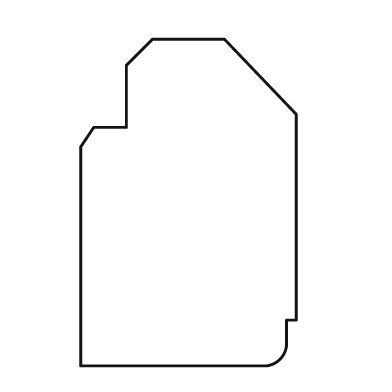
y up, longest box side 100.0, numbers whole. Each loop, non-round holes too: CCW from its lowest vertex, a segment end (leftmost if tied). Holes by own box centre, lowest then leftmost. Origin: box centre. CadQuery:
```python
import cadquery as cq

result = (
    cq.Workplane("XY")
    .moveTo(-33.0, -50.0)
    .lineTo(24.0, -50.0)
    .threePointArc((28.0, -48.0), (30.0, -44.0))
    .lineTo(30.0, -36.0)
    .lineTo(33.0, -36.0)
    .lineTo(33.0, 27.0)
    .lineTo(11.0, 50.0)
    .lineTo(-11.0, 50.0)
    .lineTo(-19.0, 42.0)
    .lineTo(-19.0, 23.0)
    .lineTo(-29.0, 23.0)
    .lineTo(-33.0, 17.0)
    .close()
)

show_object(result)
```